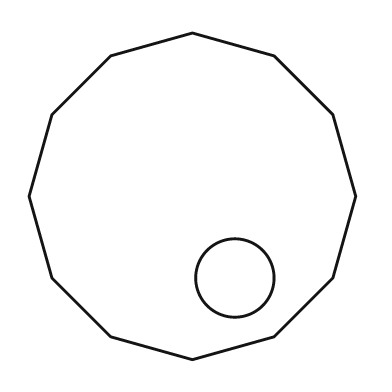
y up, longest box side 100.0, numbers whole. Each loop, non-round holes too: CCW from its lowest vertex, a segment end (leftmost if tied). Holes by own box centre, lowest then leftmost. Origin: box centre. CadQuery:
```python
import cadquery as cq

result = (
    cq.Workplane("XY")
    .moveTo(0.0, -50.0)
    .lineTo(25.0, -43.0)
    .lineTo(43.0, -25.0)
    .lineTo(50.0, 0.0)
    .lineTo(43.0, 25.0)
    .lineTo(25.0, 43.0)
    .lineTo(0.0, 50.0)
    .lineTo(-25.0, 43.0)
    .lineTo(-43.0, 25.0)
    .lineTo(-50.0, 0.0)
    .lineTo(-43.0, -25.0)
    .lineTo(-25.0, -43.0)
    .close()
    .moveTo(13.0, -25.0)
    .circle(12.0)
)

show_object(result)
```